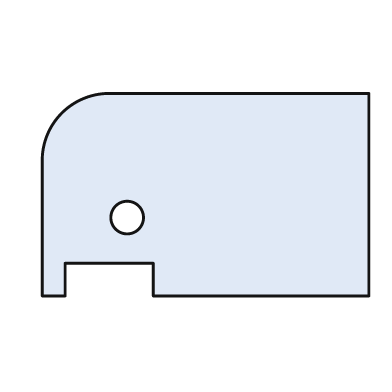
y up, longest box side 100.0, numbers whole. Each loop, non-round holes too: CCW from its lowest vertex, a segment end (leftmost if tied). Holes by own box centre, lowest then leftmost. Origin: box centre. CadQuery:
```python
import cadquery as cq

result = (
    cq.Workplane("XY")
    .moveTo(-50.0, -31.0)
    .lineTo(-43.0, -31.0)
    .lineTo(-43.0, -21.0)
    .lineTo(-16.0, -21.0)
    .lineTo(-16.0, -31.0)
    .lineTo(50.0, -31.0)
    .lineTo(50.0, 31.0)
    .lineTo(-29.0, 31.0)
    .threePointArc((-44.0, 25.0), (-50.0, 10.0))
    .close()
    .moveTo(-24.0, -7.0)
    .circle(5.0)
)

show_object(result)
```